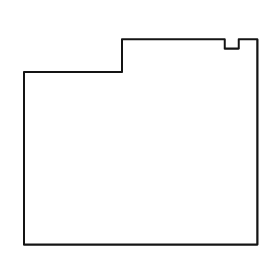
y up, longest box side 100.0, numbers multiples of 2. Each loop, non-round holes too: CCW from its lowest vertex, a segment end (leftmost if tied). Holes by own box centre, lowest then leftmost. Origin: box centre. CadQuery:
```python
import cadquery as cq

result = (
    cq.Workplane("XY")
    .moveTo(-50.0, -44.0)
    .lineTo(50.0, -44.0)
    .lineTo(50.0, 44.0)
    .lineTo(42.0, 44.0)
    .lineTo(42.0, 40.0)
    .lineTo(36.0, 40.0)
    .lineTo(36.0, 44.0)
    .lineTo(-8.0, 44.0)
    .lineTo(-8.0, 30.0)
    .lineTo(-50.0, 30.0)
    .close()
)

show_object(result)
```